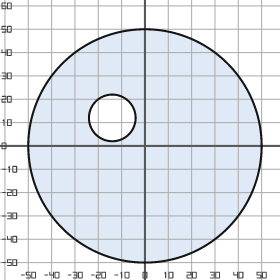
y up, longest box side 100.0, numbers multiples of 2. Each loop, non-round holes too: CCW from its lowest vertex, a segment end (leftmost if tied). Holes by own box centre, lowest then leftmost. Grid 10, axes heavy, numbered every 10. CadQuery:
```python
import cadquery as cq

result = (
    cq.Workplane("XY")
    .moveTo(0.0, 0.0)
    .circle(50.0)
    .moveTo(-14.0, 12.0)
    .circle(10.0)
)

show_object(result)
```